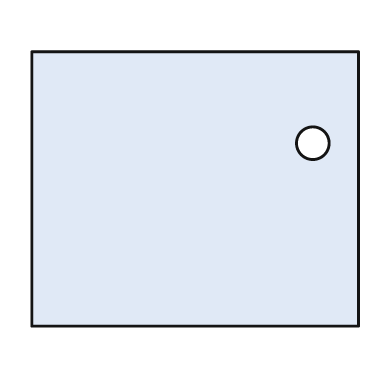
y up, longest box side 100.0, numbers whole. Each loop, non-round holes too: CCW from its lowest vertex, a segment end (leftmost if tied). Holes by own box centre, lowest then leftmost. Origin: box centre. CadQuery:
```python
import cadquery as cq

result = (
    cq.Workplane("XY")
    .moveTo(-50.0, -42.0)
    .lineTo(50.0, -42.0)
    .lineTo(50.0, 42.0)
    .lineTo(-50.0, 42.0)
    .close()
    .moveTo(36.0, 14.0)
    .circle(5.0)
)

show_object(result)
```